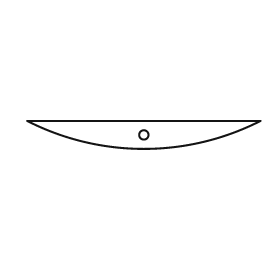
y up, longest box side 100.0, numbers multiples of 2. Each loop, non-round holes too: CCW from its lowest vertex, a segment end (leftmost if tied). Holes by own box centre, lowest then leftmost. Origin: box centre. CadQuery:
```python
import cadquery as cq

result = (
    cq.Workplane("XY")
    .moveTo(-50.0, 6.0)
    .threePointArc((0.0, -6.0), (50.0, 6.0))
    .close()
    .moveTo(0.0, 0.0)
    .circle(2.0)
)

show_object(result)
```